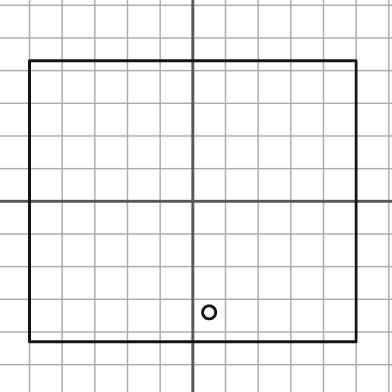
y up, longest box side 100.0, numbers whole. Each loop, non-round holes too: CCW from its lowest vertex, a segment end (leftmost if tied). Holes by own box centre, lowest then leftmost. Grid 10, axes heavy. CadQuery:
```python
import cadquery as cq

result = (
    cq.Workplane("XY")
    .moveTo(-50.0, -43.0)
    .lineTo(50.0, -43.0)
    .lineTo(50.0, 43.0)
    .lineTo(-50.0, 43.0)
    .close()
    .moveTo(5.0, -34.0)
    .circle(2.0)
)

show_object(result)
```